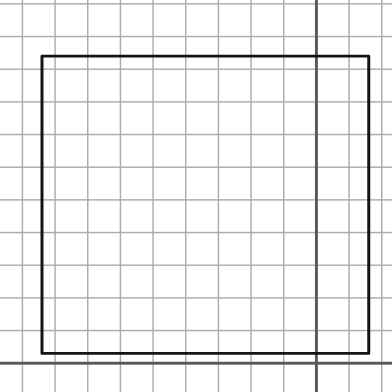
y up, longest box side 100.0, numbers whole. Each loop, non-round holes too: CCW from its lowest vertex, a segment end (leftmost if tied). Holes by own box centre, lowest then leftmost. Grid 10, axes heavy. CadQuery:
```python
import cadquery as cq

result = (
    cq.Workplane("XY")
    .moveTo(-84.0, 3.0)
    .lineTo(16.0, 3.0)
    .lineTo(16.0, 94.0)
    .lineTo(-84.0, 94.0)
    .close()
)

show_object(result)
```